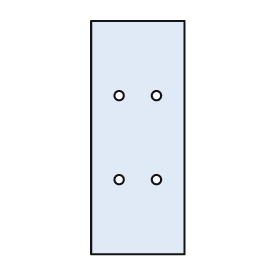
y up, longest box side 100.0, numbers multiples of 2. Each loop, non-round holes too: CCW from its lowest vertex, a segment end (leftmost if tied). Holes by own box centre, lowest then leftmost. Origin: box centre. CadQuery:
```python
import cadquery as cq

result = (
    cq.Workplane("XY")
    .moveTo(-20.0, -50.0)
    .lineTo(20.0, -50.0)
    .lineTo(20.0, 50.0)
    .lineTo(-20.0, 50.0)
    .close()
    .moveTo(-8.0, -18.0)
    .circle(2.0)
    .moveTo(8.0, -18.0)
    .circle(2.0)
    .moveTo(-8.0, 18.0)
    .circle(2.0)
    .moveTo(8.0, 18.0)
    .circle(2.0)
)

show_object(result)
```